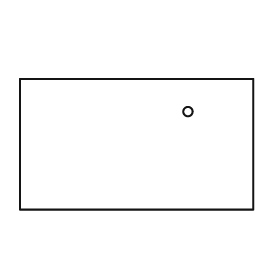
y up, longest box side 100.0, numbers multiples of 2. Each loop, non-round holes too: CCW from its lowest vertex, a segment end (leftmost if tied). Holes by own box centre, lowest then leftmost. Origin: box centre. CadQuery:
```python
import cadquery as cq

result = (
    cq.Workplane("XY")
    .moveTo(-50.0, -28.0)
    .lineTo(50.0, -28.0)
    .lineTo(50.0, 28.0)
    .lineTo(-50.0, 28.0)
    .close()
    .moveTo(22.0, 14.0)
    .circle(2.0)
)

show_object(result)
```